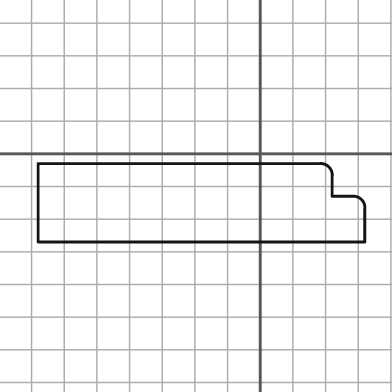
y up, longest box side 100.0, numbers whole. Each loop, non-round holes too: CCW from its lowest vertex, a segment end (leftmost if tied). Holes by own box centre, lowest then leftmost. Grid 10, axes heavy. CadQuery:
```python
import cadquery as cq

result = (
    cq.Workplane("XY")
    .moveTo(-68.0, -27.0)
    .lineTo(32.0, -27.0)
    .lineTo(32.0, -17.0)
    .threePointArc((31.0, -14.0), (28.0, -13.0))
    .lineTo(22.0, -13.0)
    .lineTo(22.0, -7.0)
    .threePointArc((21.0, -4.0), (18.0, -3.0))
    .lineTo(-68.0, -3.0)
    .close()
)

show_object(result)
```